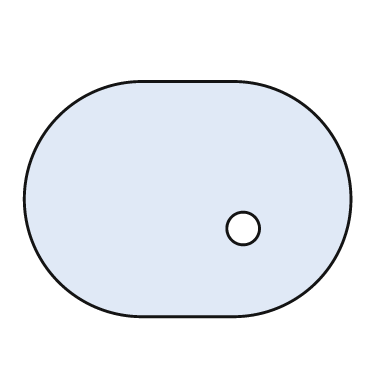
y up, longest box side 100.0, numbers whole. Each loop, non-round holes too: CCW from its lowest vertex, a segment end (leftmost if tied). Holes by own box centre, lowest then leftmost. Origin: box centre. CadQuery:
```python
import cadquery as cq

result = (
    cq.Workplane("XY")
    .moveTo(-14.0, -36.0)
    .lineTo(14.0, -36.0)
    .threePointArc((50.0, 0.0), (14.0, 36.0))
    .lineTo(-14.0, 36.0)
    .threePointArc((-50.0, 0.0), (-14.0, -36.0))
    .close()
    .moveTo(17.0, -9.0)
    .circle(5.0)
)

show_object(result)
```